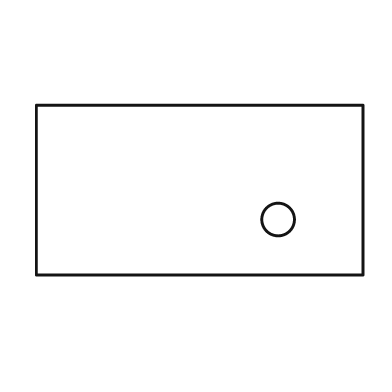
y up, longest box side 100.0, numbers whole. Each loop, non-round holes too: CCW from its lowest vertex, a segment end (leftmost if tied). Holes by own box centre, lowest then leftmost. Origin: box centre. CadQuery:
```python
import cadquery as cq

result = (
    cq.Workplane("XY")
    .moveTo(-50.0, -26.0)
    .lineTo(50.0, -26.0)
    .lineTo(50.0, 26.0)
    .lineTo(-50.0, 26.0)
    .close()
    .moveTo(24.0, -9.0)
    .circle(5.0)
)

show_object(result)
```